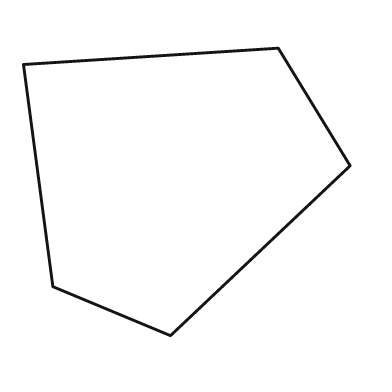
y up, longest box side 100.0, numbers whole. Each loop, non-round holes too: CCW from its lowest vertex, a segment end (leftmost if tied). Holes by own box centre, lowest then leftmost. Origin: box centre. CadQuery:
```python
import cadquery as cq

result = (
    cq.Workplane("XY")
    .moveTo(-5.0, -44.0)
    .lineTo(50.0, 8.0)
    .lineTo(28.0, 44.0)
    .lineTo(-50.0, 39.0)
    .lineTo(-41.0, -29.0)
    .close()
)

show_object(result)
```